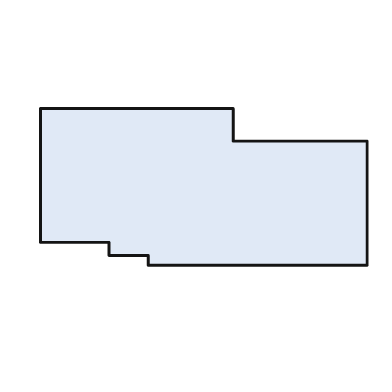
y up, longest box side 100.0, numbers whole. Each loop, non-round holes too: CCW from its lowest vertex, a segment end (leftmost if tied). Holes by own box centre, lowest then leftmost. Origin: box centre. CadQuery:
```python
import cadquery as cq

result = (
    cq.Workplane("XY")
    .moveTo(-17.0, -24.0)
    .lineTo(50.0, -24.0)
    .lineTo(50.0, 14.0)
    .lineTo(9.0, 14.0)
    .lineTo(9.0, 24.0)
    .lineTo(-50.0, 24.0)
    .lineTo(-50.0, -17.0)
    .lineTo(-29.0, -17.0)
    .lineTo(-29.0, -21.0)
    .lineTo(-17.0, -21.0)
    .close()
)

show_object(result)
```